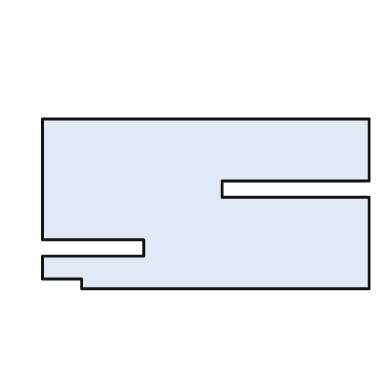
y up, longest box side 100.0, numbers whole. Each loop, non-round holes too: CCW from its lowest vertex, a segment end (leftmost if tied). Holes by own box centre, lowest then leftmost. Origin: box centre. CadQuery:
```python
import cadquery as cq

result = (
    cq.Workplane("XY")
    .moveTo(-38.0, -26.0)
    .lineTo(50.0, -26.0)
    .lineTo(50.0, 2.0)
    .lineTo(5.0, 2.0)
    .lineTo(5.0, 7.0)
    .lineTo(50.0, 7.0)
    .lineTo(50.0, 26.0)
    .lineTo(-50.0, 26.0)
    .lineTo(-50.0, -11.0)
    .lineTo(-19.0, -11.0)
    .lineTo(-19.0, -16.0)
    .lineTo(-50.0, -16.0)
    .lineTo(-50.0, -23.0)
    .lineTo(-38.0, -23.0)
    .close()
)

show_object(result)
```